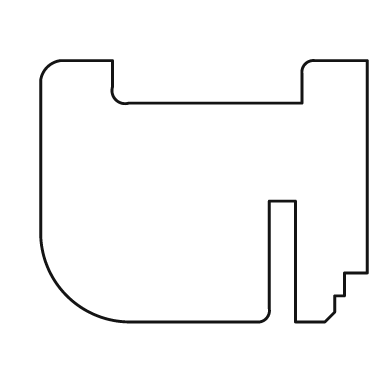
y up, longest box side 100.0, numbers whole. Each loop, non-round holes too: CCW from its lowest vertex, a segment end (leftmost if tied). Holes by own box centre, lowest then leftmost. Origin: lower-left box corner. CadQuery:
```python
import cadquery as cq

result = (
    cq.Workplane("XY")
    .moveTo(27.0, 0.0)
    .lineTo(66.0, 0.0)
    .threePointArc((69.0, 1.0), (70.0, 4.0))
    .lineTo(70.0, 37.0)
    .lineTo(78.0, 37.0)
    .lineTo(78.0, 0.0)
    .lineTo(87.0, 0.0)
    .lineTo(90.0, 3.0)
    .lineTo(90.0, 8.0)
    .lineTo(93.0, 8.0)
    .lineTo(93.0, 15.0)
    .lineTo(100.0, 15.0)
    .lineTo(100.0, 80.0)
    .lineTo(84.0, 80.0)
    .threePointArc((81.0, 79.0), (80.0, 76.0))
    .lineTo(80.0, 67.0)
    .lineTo(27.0, 67.0)
    .threePointArc((23.0, 68.0), (22.0, 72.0))
    .lineTo(22.0, 80.0)
    .lineTo(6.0, 80.0)
    .threePointArc((2.0, 78.0), (0.0, 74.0))
    .lineTo(0.0, 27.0)
    .threePointArc((8.0, 8.0), (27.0, 0.0))
    .close()
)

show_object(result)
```